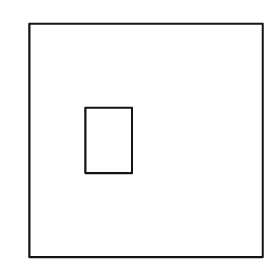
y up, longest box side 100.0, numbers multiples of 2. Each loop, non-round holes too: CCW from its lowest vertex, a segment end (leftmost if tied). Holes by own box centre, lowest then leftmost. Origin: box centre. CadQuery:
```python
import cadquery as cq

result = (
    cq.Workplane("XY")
    .moveTo(-50.0, -50.0)
    .lineTo(50.0, -50.0)
    .lineTo(50.0, 50.0)
    .lineTo(-50.0, 50.0)
    .close()
    .moveTo(-26.0, -14.0)
    .lineTo(-6.0, -14.0)
    .lineTo(-6.0, 14.0)
    .lineTo(-26.0, 14.0)
    .close()
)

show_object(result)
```